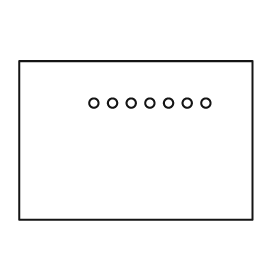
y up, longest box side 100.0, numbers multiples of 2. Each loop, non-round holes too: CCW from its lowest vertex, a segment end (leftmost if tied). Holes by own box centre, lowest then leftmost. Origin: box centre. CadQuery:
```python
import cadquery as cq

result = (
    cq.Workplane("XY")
    .moveTo(-50.0, -34.0)
    .lineTo(50.0, -34.0)
    .lineTo(50.0, 34.0)
    .lineTo(-50.0, 34.0)
    .close()
    .moveTo(-18.0, 16.0)
    .circle(2.0)
    .moveTo(-10.0, 16.0)
    .circle(2.0)
    .moveTo(-2.0, 16.0)
    .circle(2.0)
    .moveTo(6.0, 16.0)
    .circle(2.0)
    .moveTo(14.0, 16.0)
    .circle(2.0)
    .moveTo(22.0, 16.0)
    .circle(2.0)
    .moveTo(30.0, 16.0)
    .circle(2.0)
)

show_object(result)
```